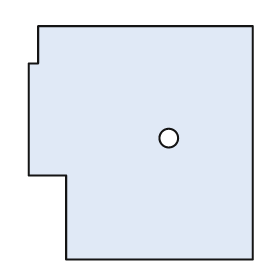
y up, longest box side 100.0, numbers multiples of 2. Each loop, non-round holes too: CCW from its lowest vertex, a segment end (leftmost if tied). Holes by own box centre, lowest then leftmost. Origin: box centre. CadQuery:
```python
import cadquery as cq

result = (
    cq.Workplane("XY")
    .moveTo(-32.0, -50.0)
    .lineTo(48.0, -50.0)
    .lineTo(48.0, 50.0)
    .lineTo(-44.0, 50.0)
    .lineTo(-44.0, 34.0)
    .lineTo(-48.0, 34.0)
    .lineTo(-48.0, -14.0)
    .lineTo(-32.0, -14.0)
    .close()
    .moveTo(12.0, 2.0)
    .circle(4.0)
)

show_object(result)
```